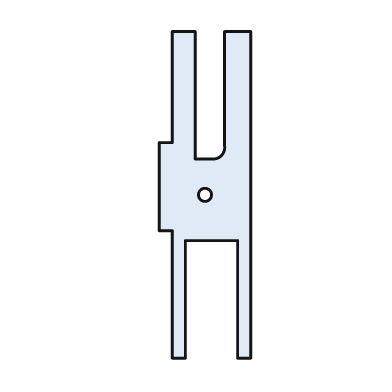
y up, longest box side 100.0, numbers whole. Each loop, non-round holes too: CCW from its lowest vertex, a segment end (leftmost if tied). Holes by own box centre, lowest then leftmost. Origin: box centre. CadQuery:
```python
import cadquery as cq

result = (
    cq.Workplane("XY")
    .moveTo(-10.0, -50.0)
    .lineTo(-6.0, -50.0)
    .lineTo(-6.0, -14.0)
    .lineTo(10.0, -14.0)
    .lineTo(10.0, -50.0)
    .lineTo(14.0, -50.0)
    .lineTo(14.0, 50.0)
    .lineTo(6.0, 50.0)
    .lineTo(6.0, 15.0)
    .threePointArc((5.0, 12.0), (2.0, 11.0))
    .lineTo(-3.0, 11.0)
    .lineTo(-3.0, 50.0)
    .lineTo(-10.0, 50.0)
    .lineTo(-10.0, 16.0)
    .lineTo(-14.0, 16.0)
    .lineTo(-14.0, -11.0)
    .lineTo(-10.0, -11.0)
    .close()
    .moveTo(0.0, 0.0)
    .circle(2.0)
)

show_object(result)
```